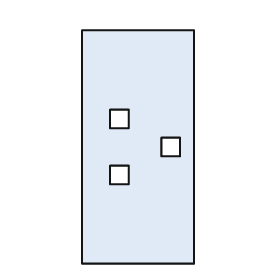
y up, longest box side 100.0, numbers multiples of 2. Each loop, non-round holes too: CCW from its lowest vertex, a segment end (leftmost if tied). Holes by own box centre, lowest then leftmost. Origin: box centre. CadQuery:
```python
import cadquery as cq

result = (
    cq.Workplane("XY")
    .moveTo(-24.0, -50.0)
    .lineTo(24.0, -50.0)
    .lineTo(24.0, 50.0)
    .lineTo(-24.0, 50.0)
    .close()
    .moveTo(-12.0, -16.0)
    .lineTo(-4.0, -16.0)
    .lineTo(-4.0, -8.0)
    .lineTo(-12.0, -8.0)
    .close()
    .moveTo(10.0, -4.0)
    .lineTo(18.0, -4.0)
    .lineTo(18.0, 4.0)
    .lineTo(10.0, 4.0)
    .close()
    .moveTo(-12.0, 8.0)
    .lineTo(-4.0, 8.0)
    .lineTo(-4.0, 16.0)
    .lineTo(-12.0, 16.0)
    .close()
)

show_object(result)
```